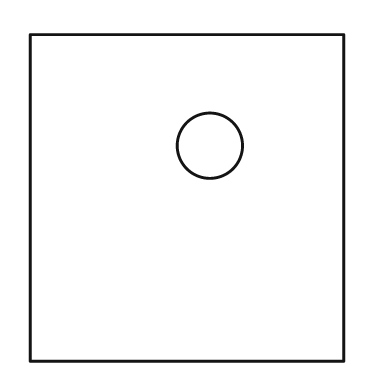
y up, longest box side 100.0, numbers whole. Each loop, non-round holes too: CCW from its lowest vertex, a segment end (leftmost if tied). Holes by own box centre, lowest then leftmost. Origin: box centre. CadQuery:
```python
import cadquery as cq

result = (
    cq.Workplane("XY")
    .moveTo(-48.0, -50.0)
    .lineTo(48.0, -50.0)
    .lineTo(48.0, 50.0)
    .lineTo(-48.0, 50.0)
    .close()
    .moveTo(7.0, 16.0)
    .circle(10.0)
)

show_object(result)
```